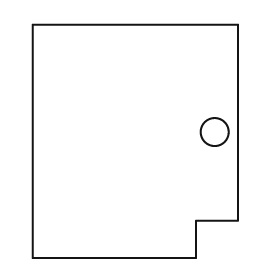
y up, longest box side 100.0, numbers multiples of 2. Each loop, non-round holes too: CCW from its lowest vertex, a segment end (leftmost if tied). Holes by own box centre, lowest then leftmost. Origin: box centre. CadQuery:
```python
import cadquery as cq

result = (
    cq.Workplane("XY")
    .moveTo(-44.0, -50.0)
    .lineTo(26.0, -50.0)
    .lineTo(26.0, -34.0)
    .lineTo(44.0, -34.0)
    .lineTo(44.0, 50.0)
    .lineTo(-44.0, 50.0)
    .close()
    .moveTo(34.0, 4.0)
    .circle(6.0)
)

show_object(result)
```